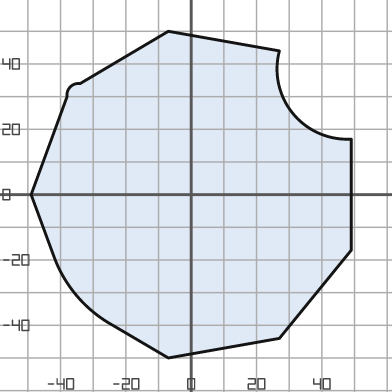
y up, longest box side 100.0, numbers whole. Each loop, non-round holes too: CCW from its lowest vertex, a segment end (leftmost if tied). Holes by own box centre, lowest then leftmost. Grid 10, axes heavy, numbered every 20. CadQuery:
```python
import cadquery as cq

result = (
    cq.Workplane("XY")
    .moveTo(-7.0, -50.0)
    .lineTo(27.0, -44.0)
    .lineTo(49.0, -17.0)
    .lineTo(49.0, 17.0)
    .threePointArc((31.0, 25.0), (27.0, 44.0))
    .lineTo(-7.0, 50.0)
    .lineTo(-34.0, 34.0)
    .threePointArc((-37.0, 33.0), (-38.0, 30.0))
    .lineTo(-49.0, 0.0)
    .lineTo(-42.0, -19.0)
    .threePointArc((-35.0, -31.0), (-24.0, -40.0))
    .close()
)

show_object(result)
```